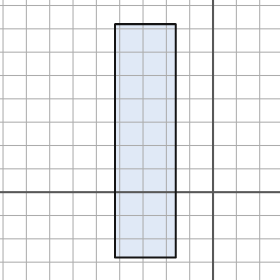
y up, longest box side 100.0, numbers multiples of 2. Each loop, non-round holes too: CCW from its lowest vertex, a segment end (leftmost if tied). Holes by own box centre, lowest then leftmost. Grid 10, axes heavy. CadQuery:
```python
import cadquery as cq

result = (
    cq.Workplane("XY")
    .moveTo(-42.0, -28.0)
    .lineTo(-16.0, -28.0)
    .lineTo(-16.0, 72.0)
    .lineTo(-42.0, 72.0)
    .close()
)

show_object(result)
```